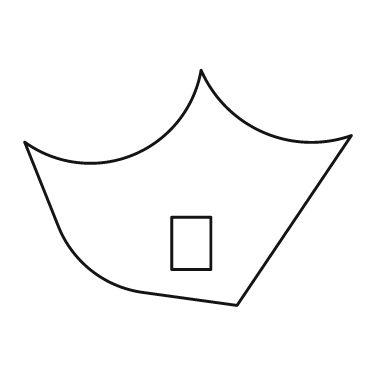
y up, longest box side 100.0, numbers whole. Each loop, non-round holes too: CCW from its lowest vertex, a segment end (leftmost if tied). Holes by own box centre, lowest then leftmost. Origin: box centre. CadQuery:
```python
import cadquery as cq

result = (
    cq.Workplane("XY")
    .moveTo(15.0, -36.0)
    .lineTo(50.0, 16.0)
    .threePointArc((23.0, 17.0), (4.0, 36.0))
    .threePointArc((-17.0, 10.0), (-50.0, 14.0))
    .lineTo(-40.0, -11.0)
    .threePointArc((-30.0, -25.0), (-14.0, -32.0))
    .close()
    .moveTo(-5.0, -25.0)
    .lineTo(7.0, -25.0)
    .lineTo(7.0, -9.0)
    .lineTo(-5.0, -9.0)
    .close()
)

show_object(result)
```